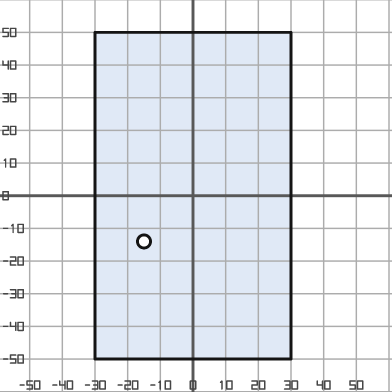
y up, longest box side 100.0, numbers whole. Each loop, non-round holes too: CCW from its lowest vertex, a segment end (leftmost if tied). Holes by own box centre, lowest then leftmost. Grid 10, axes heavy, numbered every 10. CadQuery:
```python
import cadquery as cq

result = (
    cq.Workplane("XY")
    .moveTo(-30.0, -50.0)
    .lineTo(30.0, -50.0)
    .lineTo(30.0, 50.0)
    .lineTo(-30.0, 50.0)
    .close()
    .moveTo(-15.0, -14.0)
    .circle(2.0)
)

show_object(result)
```